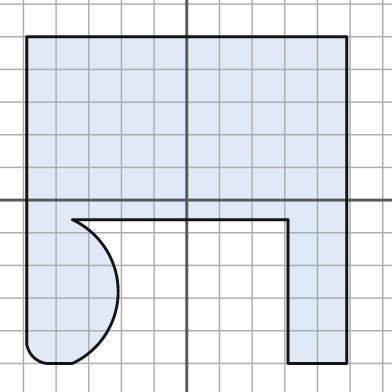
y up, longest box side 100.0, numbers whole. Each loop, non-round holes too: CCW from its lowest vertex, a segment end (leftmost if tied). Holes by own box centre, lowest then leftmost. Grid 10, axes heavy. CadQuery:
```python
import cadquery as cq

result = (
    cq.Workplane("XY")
    .moveTo(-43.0, -50.0)
    .lineTo(-35.0, -50.0)
    .threePointArc((-21.0, -28.0), (-35.0, -6.0))
    .lineTo(31.0, -6.0)
    .lineTo(31.0, -50.0)
    .lineTo(49.0, -50.0)
    .lineTo(49.0, 50.0)
    .lineTo(-49.0, 50.0)
    .lineTo(-49.0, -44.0)
    .threePointArc((-47.0, -48.0), (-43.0, -50.0))
    .close()
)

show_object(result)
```